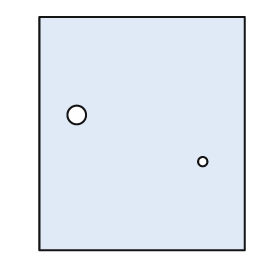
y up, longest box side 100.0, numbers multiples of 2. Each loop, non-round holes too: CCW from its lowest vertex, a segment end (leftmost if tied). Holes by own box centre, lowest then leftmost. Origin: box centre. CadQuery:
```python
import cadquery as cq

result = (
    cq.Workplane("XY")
    .moveTo(-44.0, -50.0)
    .lineTo(44.0, -50.0)
    .lineTo(44.0, 50.0)
    .lineTo(-44.0, 50.0)
    .close()
    .moveTo(26.0, -12.0)
    .circle(2.0)
    .moveTo(-28.0, 8.0)
    .circle(4.0)
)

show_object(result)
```